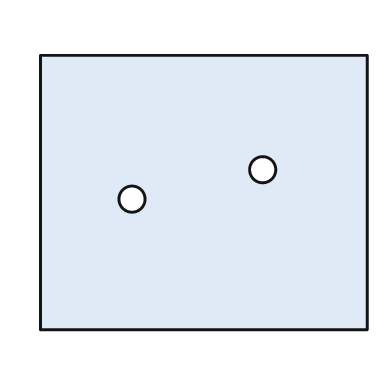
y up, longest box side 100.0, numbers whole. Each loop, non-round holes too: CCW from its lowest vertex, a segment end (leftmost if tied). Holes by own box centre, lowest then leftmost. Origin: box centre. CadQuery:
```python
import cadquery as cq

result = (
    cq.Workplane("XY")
    .moveTo(-50.0, -42.0)
    .lineTo(50.0, -42.0)
    .lineTo(50.0, 42.0)
    .lineTo(-50.0, 42.0)
    .close()
    .moveTo(-22.0, -2.0)
    .circle(4.0)
    .moveTo(18.0, 7.0)
    .circle(4.0)
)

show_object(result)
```